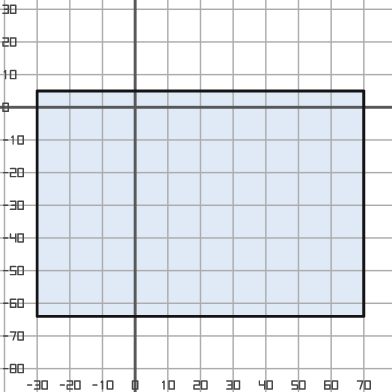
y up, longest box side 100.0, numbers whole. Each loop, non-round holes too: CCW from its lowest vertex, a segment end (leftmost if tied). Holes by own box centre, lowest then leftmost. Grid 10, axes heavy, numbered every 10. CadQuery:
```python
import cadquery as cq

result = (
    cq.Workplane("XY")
    .moveTo(-30.0, -64.0)
    .lineTo(70.0, -64.0)
    .lineTo(70.0, 5.0)
    .lineTo(-30.0, 5.0)
    .close()
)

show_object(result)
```